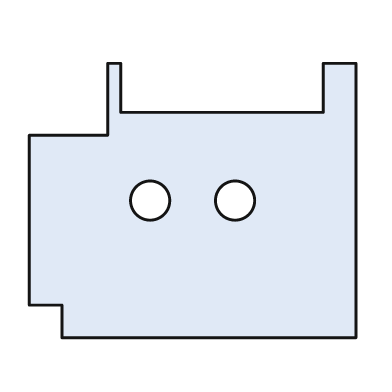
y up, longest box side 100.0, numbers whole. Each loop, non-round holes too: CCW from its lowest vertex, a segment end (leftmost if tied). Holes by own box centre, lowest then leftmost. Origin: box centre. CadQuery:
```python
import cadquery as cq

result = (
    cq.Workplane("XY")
    .moveTo(-40.0, -42.0)
    .lineTo(50.0, -42.0)
    .lineTo(50.0, 42.0)
    .lineTo(40.0, 42.0)
    .lineTo(40.0, 27.0)
    .lineTo(-22.0, 27.0)
    .lineTo(-22.0, 42.0)
    .lineTo(-26.0, 42.0)
    .lineTo(-26.0, 20.0)
    .lineTo(-50.0, 20.0)
    .lineTo(-50.0, -32.0)
    .lineTo(-40.0, -32.0)
    .close()
    .moveTo(-13.0, 0.0)
    .circle(6.0)
    .moveTo(13.0, 0.0)
    .circle(6.0)
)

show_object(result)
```